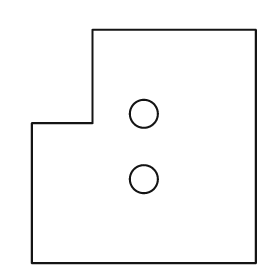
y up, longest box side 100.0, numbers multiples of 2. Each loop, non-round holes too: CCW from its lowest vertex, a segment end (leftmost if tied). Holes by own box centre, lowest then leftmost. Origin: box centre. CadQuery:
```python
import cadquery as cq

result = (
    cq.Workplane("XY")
    .moveTo(-48.0, -50.0)
    .lineTo(48.0, -50.0)
    .lineTo(48.0, 50.0)
    .lineTo(-22.0, 50.0)
    .lineTo(-22.0, 10.0)
    .lineTo(-48.0, 10.0)
    .close()
    .moveTo(0.0, -14.0)
    .circle(6.0)
    .moveTo(0.0, 14.0)
    .circle(6.0)
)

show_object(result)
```